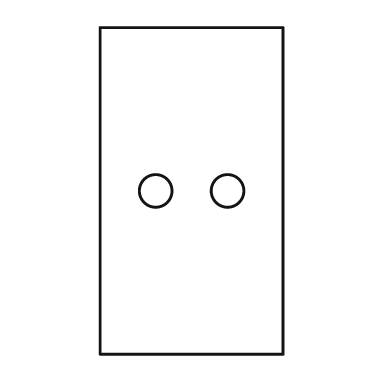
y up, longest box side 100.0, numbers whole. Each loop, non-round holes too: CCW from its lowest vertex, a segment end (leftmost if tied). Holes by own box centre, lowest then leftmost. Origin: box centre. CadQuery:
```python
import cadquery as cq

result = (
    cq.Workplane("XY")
    .moveTo(-28.0, -50.0)
    .lineTo(28.0, -50.0)
    .lineTo(28.0, 50.0)
    .lineTo(-28.0, 50.0)
    .close()
    .moveTo(-11.0, 0.0)
    .circle(5.0)
    .moveTo(11.0, 0.0)
    .circle(5.0)
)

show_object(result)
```